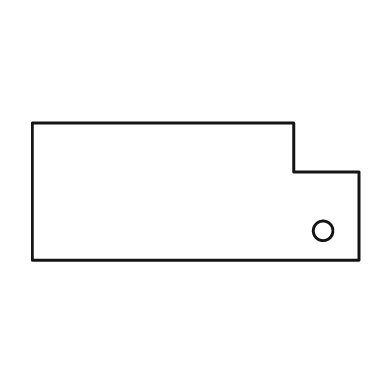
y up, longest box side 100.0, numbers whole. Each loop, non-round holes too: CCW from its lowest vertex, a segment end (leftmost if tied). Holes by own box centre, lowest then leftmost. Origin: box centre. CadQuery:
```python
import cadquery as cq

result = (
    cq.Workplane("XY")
    .moveTo(-50.0, -21.0)
    .lineTo(50.0, -21.0)
    .lineTo(50.0, 6.0)
    .lineTo(30.0, 6.0)
    .lineTo(30.0, 21.0)
    .lineTo(-50.0, 21.0)
    .close()
    .moveTo(39.0, -12.0)
    .circle(3.0)
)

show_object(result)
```